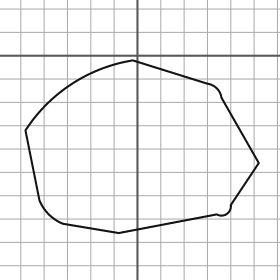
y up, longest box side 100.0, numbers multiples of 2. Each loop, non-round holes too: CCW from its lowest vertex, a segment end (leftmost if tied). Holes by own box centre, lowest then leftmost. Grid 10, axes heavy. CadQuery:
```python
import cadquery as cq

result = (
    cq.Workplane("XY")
    .moveTo(-8.0, -76.0)
    .lineTo(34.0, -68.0)
    .threePointArc((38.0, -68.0), (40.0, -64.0))
    .lineTo(52.0, -46.0)
    .lineTo(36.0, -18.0)
    .threePointArc((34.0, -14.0), (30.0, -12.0))
    .lineTo(-2.0, -2.0)
    .threePointArc((-28.0, -12.0), (-48.0, -32.0))
    .lineTo(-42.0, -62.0)
    .threePointArc((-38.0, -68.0), (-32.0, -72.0))
    .close()
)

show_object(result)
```